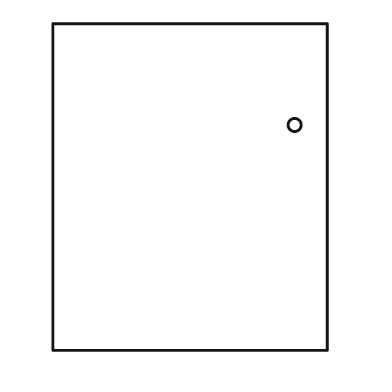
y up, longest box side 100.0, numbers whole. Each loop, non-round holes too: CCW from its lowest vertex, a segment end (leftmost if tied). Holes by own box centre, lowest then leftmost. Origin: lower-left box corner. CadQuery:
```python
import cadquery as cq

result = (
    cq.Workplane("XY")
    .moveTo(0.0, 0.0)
    .lineTo(84.0, 0.0)
    .lineTo(84.0, 100.0)
    .lineTo(0.0, 100.0)
    .close()
    .moveTo(74.0, 69.0)
    .circle(2.0)
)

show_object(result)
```